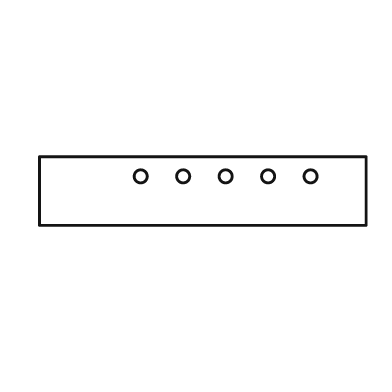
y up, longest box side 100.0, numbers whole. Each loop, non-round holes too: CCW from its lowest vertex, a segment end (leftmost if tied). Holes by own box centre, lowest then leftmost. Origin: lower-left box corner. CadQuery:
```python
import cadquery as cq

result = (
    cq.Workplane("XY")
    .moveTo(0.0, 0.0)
    .lineTo(100.0, 0.0)
    .lineTo(100.0, 21.0)
    .lineTo(0.0, 21.0)
    .close()
    .moveTo(31.0, 15.0)
    .circle(2.0)
    .moveTo(44.0, 15.0)
    .circle(2.0)
    .moveTo(57.0, 15.0)
    .circle(2.0)
    .moveTo(70.0, 15.0)
    .circle(2.0)
    .moveTo(83.0, 15.0)
    .circle(2.0)
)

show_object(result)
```